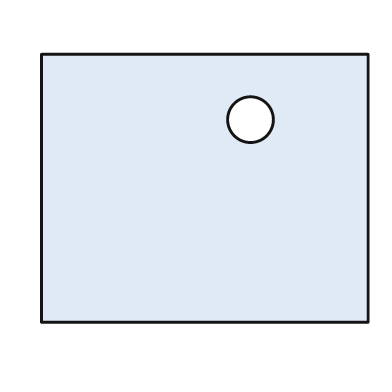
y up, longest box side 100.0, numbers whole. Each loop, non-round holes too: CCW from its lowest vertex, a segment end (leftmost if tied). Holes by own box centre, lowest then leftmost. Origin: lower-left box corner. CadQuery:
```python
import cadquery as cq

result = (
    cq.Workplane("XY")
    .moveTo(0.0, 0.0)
    .lineTo(100.0, 0.0)
    .lineTo(100.0, 82.0)
    .lineTo(0.0, 82.0)
    .close()
    .moveTo(64.0, 62.0)
    .circle(7.0)
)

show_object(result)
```